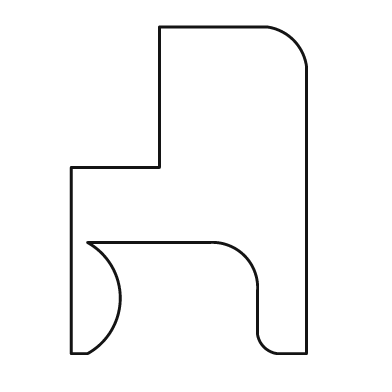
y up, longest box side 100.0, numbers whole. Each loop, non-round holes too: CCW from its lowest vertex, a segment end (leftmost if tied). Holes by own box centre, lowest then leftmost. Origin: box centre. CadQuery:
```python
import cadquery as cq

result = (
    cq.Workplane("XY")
    .moveTo(-36.0, -50.0)
    .lineTo(-31.0, -50.0)
    .threePointArc((-21.0, -33.0), (-31.0, -16.0))
    .lineTo(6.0, -16.0)
    .threePointArc((17.0, -20.0), (21.0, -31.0))
    .lineTo(21.0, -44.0)
    .threePointArc((23.0, -48.0), (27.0, -50.0))
    .lineTo(36.0, -50.0)
    .lineTo(36.0, 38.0)
    .threePointArc((32.0, 46.0), (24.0, 50.0))
    .lineTo(-9.0, 50.0)
    .lineTo(-9.0, 7.0)
    .lineTo(-36.0, 7.0)
    .close()
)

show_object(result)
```